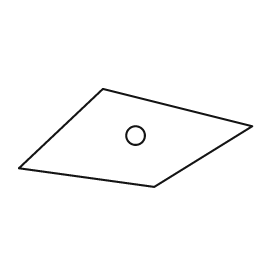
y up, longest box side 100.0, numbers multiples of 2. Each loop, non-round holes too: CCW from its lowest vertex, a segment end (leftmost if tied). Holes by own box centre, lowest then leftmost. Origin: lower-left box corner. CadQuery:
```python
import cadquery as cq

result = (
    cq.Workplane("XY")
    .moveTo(58.0, 0.0)
    .lineTo(100.0, 26.0)
    .lineTo(36.0, 42.0)
    .lineTo(0.0, 8.0)
    .close()
    .moveTo(50.0, 22.0)
    .circle(4.0)
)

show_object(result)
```